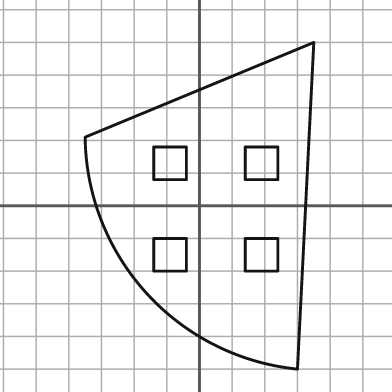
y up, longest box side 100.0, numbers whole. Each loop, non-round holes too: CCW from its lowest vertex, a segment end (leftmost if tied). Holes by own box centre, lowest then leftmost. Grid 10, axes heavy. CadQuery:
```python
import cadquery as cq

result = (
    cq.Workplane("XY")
    .moveTo(30.0, -50.0)
    .lineTo(35.0, 50.0)
    .lineTo(-35.0, 21.0)
    .threePointArc((-16.0, -27.0), (30.0, -50.0))
    .close()
    .moveTo(-14.0, -20.0)
    .lineTo(-4.0, -20.0)
    .lineTo(-4.0, -10.0)
    .lineTo(-14.0, -10.0)
    .close()
    .moveTo(14.0, -20.0)
    .lineTo(24.0, -20.0)
    .lineTo(24.0, -10.0)
    .lineTo(14.0, -10.0)
    .close()
    .moveTo(-14.0, 8.0)
    .lineTo(-4.0, 8.0)
    .lineTo(-4.0, 18.0)
    .lineTo(-14.0, 18.0)
    .close()
    .moveTo(14.0, 8.0)
    .lineTo(24.0, 8.0)
    .lineTo(24.0, 18.0)
    .lineTo(14.0, 18.0)
    .close()
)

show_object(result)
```